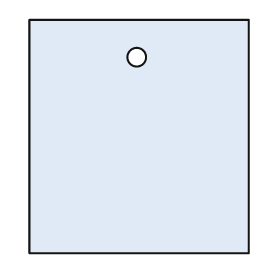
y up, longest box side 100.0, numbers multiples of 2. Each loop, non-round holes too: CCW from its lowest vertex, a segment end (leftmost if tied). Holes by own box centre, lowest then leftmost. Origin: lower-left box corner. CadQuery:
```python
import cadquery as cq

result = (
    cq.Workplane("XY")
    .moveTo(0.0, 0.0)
    .lineTo(94.0, 0.0)
    .lineTo(94.0, 100.0)
    .lineTo(0.0, 100.0)
    .close()
    .moveTo(46.0, 84.0)
    .circle(4.0)
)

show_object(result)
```